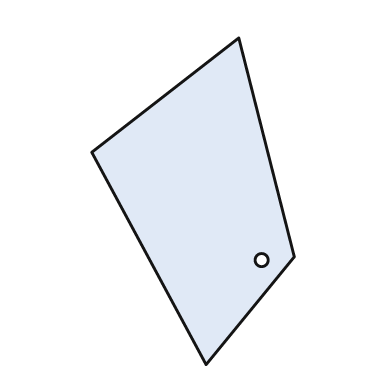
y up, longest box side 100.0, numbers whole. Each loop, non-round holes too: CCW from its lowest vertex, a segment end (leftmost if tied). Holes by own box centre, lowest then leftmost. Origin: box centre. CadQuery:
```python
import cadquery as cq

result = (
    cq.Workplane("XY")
    .moveTo(4.0, -50.0)
    .lineTo(31.0, -17.0)
    .lineTo(14.0, 50.0)
    .lineTo(-31.0, 15.0)
    .close()
    .moveTo(21.0, -18.0)
    .circle(2.0)
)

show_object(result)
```